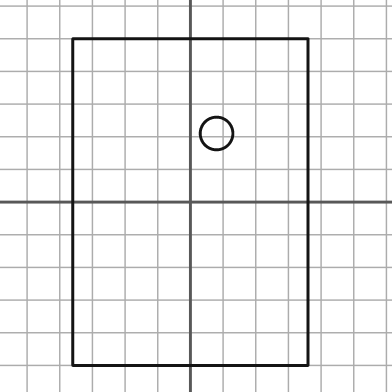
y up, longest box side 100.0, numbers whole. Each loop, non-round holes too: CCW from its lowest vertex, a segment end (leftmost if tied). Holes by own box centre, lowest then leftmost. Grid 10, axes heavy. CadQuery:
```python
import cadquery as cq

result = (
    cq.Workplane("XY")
    .moveTo(-36.0, -50.0)
    .lineTo(36.0, -50.0)
    .lineTo(36.0, 50.0)
    .lineTo(-36.0, 50.0)
    .close()
    .moveTo(8.0, 21.0)
    .circle(5.0)
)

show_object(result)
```